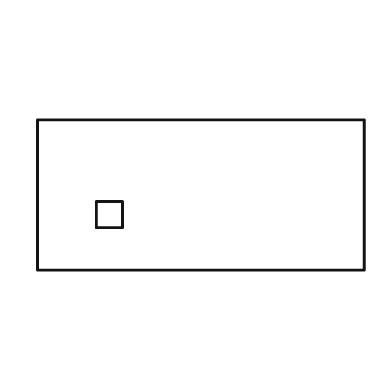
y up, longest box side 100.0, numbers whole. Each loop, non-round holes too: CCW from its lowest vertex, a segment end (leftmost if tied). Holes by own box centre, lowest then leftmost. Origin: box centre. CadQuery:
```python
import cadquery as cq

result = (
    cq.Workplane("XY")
    .moveTo(-50.0, -23.0)
    .lineTo(50.0, -23.0)
    .lineTo(50.0, 23.0)
    .lineTo(-50.0, 23.0)
    .close()
    .moveTo(-32.0, -10.0)
    .lineTo(-24.0, -10.0)
    .lineTo(-24.0, -2.0)
    .lineTo(-32.0, -2.0)
    .close()
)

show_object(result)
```